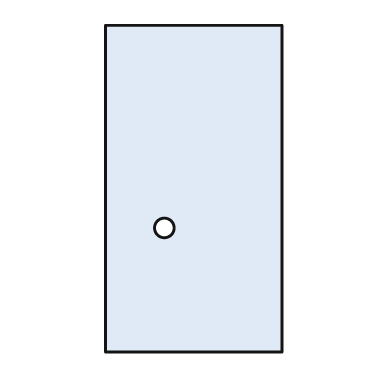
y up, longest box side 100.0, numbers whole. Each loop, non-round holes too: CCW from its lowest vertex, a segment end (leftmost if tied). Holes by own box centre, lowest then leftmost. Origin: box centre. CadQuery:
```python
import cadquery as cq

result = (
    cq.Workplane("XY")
    .moveTo(-27.0, -50.0)
    .lineTo(27.0, -50.0)
    .lineTo(27.0, 50.0)
    .lineTo(-27.0, 50.0)
    .close()
    .moveTo(-9.0, -12.0)
    .circle(3.0)
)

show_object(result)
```